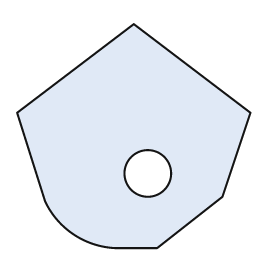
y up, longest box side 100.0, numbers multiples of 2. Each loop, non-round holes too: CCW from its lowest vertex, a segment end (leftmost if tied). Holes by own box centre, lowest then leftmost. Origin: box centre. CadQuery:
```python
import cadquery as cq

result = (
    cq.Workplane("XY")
    .moveTo(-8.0, -48.0)
    .lineTo(10.0, -48.0)
    .lineTo(38.0, -26.0)
    .lineTo(50.0, 10.0)
    .lineTo(0.0, 48.0)
    .lineTo(-50.0, 10.0)
    .lineTo(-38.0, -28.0)
    .threePointArc((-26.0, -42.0), (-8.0, -48.0))
    .close()
    .moveTo(6.0, -16.0)
    .circle(10.0)
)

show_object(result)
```